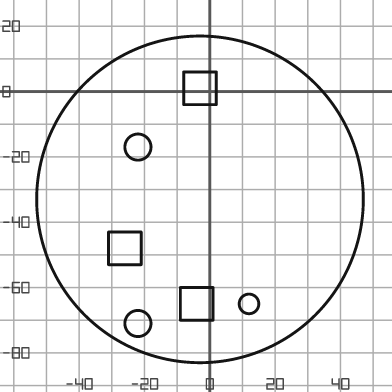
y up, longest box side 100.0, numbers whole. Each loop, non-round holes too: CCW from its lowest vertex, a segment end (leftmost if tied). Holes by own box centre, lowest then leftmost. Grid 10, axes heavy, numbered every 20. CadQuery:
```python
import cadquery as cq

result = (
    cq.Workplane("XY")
    .moveTo(-3.0, -33.0)
    .circle(50.0)
    .moveTo(-22.0, -71.0)
    .circle(4.0)
    .moveTo(-9.0, -70.0)
    .lineTo(1.0, -70.0)
    .lineTo(1.0, -60.0)
    .lineTo(-9.0, -60.0)
    .close()
    .moveTo(12.0, -65.0)
    .circle(3.0)
    .moveTo(-31.0, -53.0)
    .lineTo(-21.0, -53.0)
    .lineTo(-21.0, -43.0)
    .lineTo(-31.0, -43.0)
    .close()
    .moveTo(-22.0, -17.0)
    .circle(4.0)
    .moveTo(-8.0, -4.0)
    .lineTo(2.0, -4.0)
    .lineTo(2.0, 6.0)
    .lineTo(-8.0, 6.0)
    .close()
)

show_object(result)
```